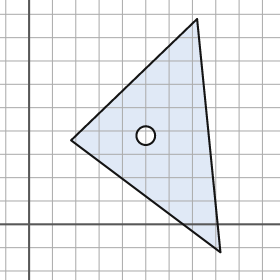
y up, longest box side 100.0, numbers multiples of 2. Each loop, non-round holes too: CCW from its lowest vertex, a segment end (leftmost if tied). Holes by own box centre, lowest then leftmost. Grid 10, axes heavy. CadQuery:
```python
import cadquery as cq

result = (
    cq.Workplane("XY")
    .moveTo(82.0, -12.0)
    .lineTo(72.0, 88.0)
    .lineTo(18.0, 36.0)
    .close()
    .moveTo(50.0, 38.0)
    .circle(4.0)
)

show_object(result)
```